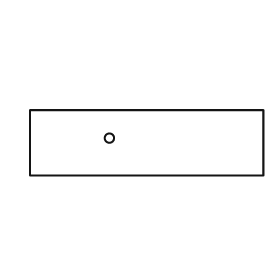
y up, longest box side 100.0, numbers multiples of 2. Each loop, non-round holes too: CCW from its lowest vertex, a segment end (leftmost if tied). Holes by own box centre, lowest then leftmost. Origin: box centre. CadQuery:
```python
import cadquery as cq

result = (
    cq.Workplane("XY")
    .moveTo(-50.0, -14.0)
    .lineTo(50.0, -14.0)
    .lineTo(50.0, 14.0)
    .lineTo(-50.0, 14.0)
    .close()
    .moveTo(-16.0, 2.0)
    .circle(2.0)
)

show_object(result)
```